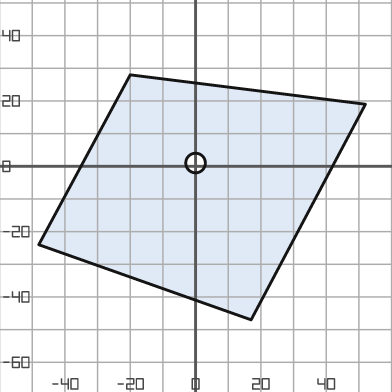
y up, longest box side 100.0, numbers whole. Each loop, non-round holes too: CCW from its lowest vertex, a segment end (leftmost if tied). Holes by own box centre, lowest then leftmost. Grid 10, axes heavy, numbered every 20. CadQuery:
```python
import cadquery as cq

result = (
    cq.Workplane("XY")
    .moveTo(17.0, -47.0)
    .lineTo(52.0, 19.0)
    .lineTo(-20.0, 28.0)
    .lineTo(-48.0, -24.0)
    .close()
    .moveTo(0.0, 1.0)
    .circle(3.0)
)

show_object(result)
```